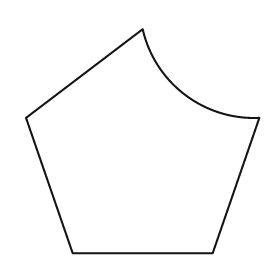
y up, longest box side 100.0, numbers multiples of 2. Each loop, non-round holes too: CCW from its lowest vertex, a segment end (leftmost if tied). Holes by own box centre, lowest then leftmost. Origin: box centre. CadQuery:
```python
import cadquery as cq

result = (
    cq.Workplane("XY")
    .moveTo(-30.0, -48.0)
    .lineTo(30.0, -48.0)
    .lineTo(50.0, 10.0)
    .threePointArc((18.0, 20.0), (0.0, 48.0))
    .lineTo(-50.0, 10.0)
    .close()
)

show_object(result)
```